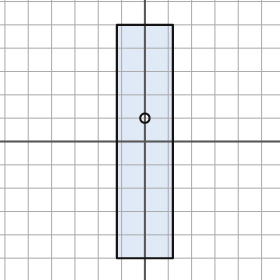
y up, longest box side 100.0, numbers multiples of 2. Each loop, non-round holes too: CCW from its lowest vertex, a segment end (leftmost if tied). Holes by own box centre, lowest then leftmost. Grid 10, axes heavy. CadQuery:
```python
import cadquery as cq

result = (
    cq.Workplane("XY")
    .moveTo(-12.0, -50.0)
    .lineTo(12.0, -50.0)
    .lineTo(12.0, 50.0)
    .lineTo(-12.0, 50.0)
    .close()
    .moveTo(0.0, 10.0)
    .circle(2.0)
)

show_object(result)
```